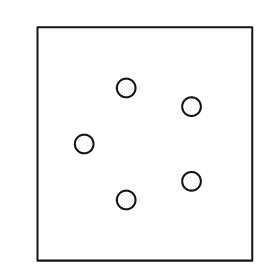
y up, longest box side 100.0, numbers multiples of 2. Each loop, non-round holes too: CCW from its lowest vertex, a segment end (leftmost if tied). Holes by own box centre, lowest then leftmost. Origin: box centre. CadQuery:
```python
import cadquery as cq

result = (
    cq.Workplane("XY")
    .moveTo(-46.0, -50.0)
    .lineTo(46.0, -50.0)
    .lineTo(46.0, 50.0)
    .lineTo(-46.0, 50.0)
    .close()
    .moveTo(-8.0, -24.0)
    .circle(4.0)
    .moveTo(20.0, -16.0)
    .circle(4.0)
    .moveTo(-26.0, 0.0)
    .circle(4.0)
    .moveTo(20.0, 16.0)
    .circle(4.0)
    .moveTo(-8.0, 24.0)
    .circle(4.0)
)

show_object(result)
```